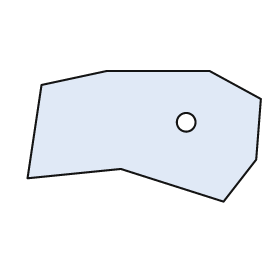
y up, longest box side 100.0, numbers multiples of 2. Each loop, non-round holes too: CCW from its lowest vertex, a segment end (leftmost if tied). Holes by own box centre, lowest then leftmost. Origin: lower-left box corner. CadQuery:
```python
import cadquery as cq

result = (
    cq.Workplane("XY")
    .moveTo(84.0, 0.0)
    .lineTo(98.0, 18.0)
    .lineTo(100.0, 44.0)
    .lineTo(78.0, 56.0)
    .lineTo(34.0, 56.0)
    .lineTo(6.0, 50.0)
    .lineTo(0.0, 10.0)
    .lineTo(40.0, 14.0)
    .close()
    .moveTo(68.0, 34.0)
    .circle(4.0)
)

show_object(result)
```